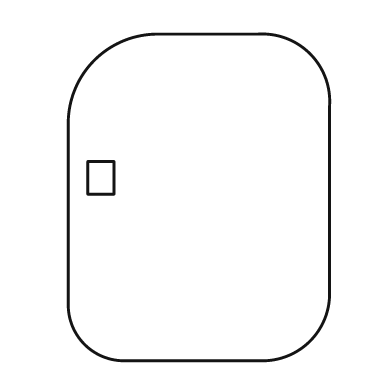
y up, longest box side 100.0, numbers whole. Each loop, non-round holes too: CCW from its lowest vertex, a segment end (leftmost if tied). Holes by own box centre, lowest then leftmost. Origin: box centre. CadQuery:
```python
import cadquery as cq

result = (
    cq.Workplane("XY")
    .moveTo(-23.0, -50.0)
    .lineTo(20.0, -50.0)
    .threePointArc((34.0, -44.0), (40.0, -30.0))
    .lineTo(40.0, 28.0)
    .threePointArc((34.0, 44.0), (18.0, 50.0))
    .lineTo(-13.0, 50.0)
    .threePointArc((-32.0, 42.0), (-40.0, 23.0))
    .lineTo(-40.0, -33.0)
    .threePointArc((-35.0, -45.0), (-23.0, -50.0))
    .close()
    .moveTo(-34.0, 1.0)
    .lineTo(-26.0, 1.0)
    .lineTo(-26.0, 11.0)
    .lineTo(-34.0, 11.0)
    .close()
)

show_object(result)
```